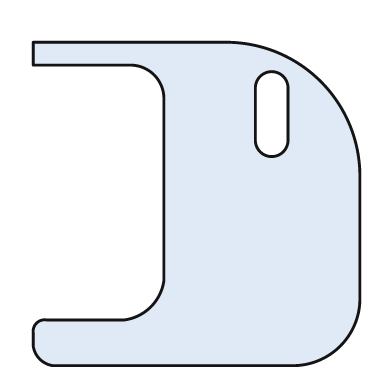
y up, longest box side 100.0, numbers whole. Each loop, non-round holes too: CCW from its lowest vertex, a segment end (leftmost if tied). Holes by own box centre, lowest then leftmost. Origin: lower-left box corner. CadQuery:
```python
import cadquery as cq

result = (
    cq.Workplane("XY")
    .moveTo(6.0, 0.0)
    .lineTo(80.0, 0.0)
    .threePointArc((94.0, 6.0), (100.0, 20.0))
    .lineTo(100.0, 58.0)
    .threePointArc((88.0, 87.0), (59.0, 99.0))
    .lineTo(0.0, 99.0)
    .lineTo(0.0, 92.0)
    .lineTo(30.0, 92.0)
    .threePointArc((37.0, 89.0), (40.0, 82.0))
    .lineTo(40.0, 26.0)
    .threePointArc((36.0, 18.0), (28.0, 14.0))
    .lineTo(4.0, 14.0)
    .threePointArc((1.0, 13.0), (0.0, 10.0))
    .lineTo(0.0, 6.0)
    .threePointArc((2.0, 2.0), (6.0, 0.0))
    .close()
    .moveTo(68.0, 69.0)
    .threePointArc((73.0, 64.0), (78.0, 69.0))
    .lineTo(78.0, 85.0)
    .threePointArc((73.0, 90.0), (68.0, 85.0))
    .close()
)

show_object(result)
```